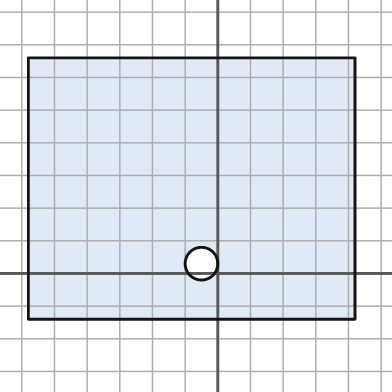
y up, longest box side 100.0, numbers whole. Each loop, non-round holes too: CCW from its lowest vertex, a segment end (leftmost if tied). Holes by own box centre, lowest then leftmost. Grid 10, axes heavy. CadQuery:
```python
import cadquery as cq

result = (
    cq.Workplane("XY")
    .moveTo(-58.0, -14.0)
    .lineTo(42.0, -14.0)
    .lineTo(42.0, 66.0)
    .lineTo(-58.0, 66.0)
    .close()
    .moveTo(-5.0, 3.0)
    .circle(5.0)
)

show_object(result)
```